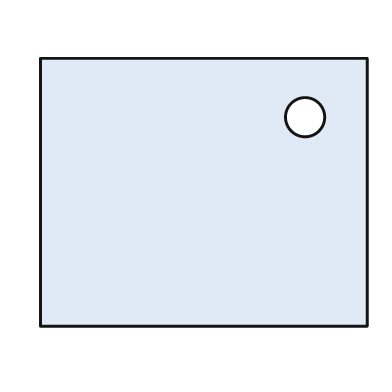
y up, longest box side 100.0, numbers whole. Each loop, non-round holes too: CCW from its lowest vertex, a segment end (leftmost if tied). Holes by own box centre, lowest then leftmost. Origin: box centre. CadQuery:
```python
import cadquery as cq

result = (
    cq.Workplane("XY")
    .moveTo(-50.0, -41.0)
    .lineTo(50.0, -41.0)
    .lineTo(50.0, 41.0)
    .lineTo(-50.0, 41.0)
    .close()
    .moveTo(31.0, 23.0)
    .circle(6.0)
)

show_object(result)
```